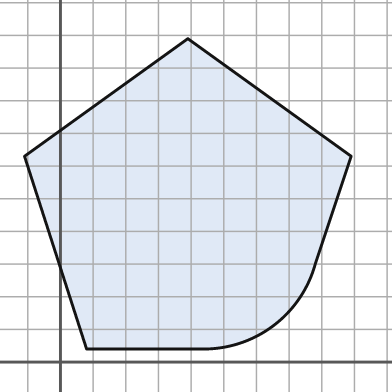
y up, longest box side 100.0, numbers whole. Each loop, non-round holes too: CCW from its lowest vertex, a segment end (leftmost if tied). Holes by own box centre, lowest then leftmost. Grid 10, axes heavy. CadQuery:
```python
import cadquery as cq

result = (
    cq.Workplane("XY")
    .moveTo(8.0, 4.0)
    .lineTo(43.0, 4.0)
    .threePointArc((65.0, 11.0), (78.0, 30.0))
    .lineTo(89.0, 63.0)
    .lineTo(39.0, 99.0)
    .lineTo(-11.0, 63.0)
    .close()
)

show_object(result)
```